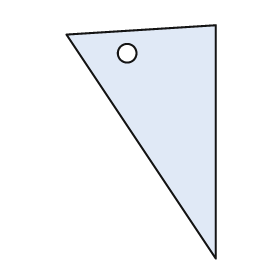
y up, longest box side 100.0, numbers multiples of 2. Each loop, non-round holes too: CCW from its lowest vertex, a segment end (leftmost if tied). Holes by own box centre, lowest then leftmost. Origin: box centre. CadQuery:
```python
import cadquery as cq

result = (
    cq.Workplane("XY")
    .moveTo(32.0, -50.0)
    .lineTo(32.0, 50.0)
    .lineTo(-32.0, 46.0)
    .close()
    .moveTo(-6.0, 38.0)
    .circle(4.0)
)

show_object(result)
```